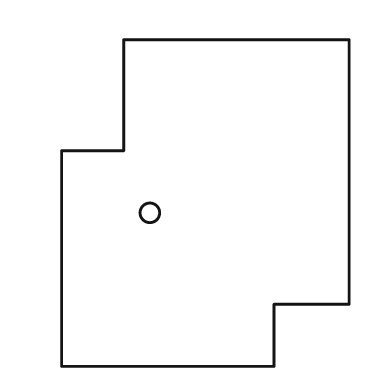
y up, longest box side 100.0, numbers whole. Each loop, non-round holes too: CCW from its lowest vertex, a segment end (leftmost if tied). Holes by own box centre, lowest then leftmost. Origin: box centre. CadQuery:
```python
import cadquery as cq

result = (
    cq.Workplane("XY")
    .moveTo(-44.0, -50.0)
    .lineTo(21.0, -50.0)
    .lineTo(21.0, -31.0)
    .lineTo(44.0, -31.0)
    .lineTo(44.0, 50.0)
    .lineTo(-25.0, 50.0)
    .lineTo(-25.0, 16.0)
    .lineTo(-44.0, 16.0)
    .close()
    .moveTo(-17.0, -3.0)
    .circle(3.0)
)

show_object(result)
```